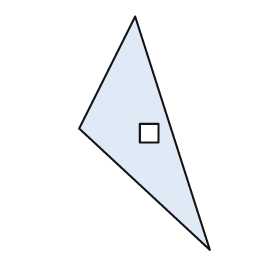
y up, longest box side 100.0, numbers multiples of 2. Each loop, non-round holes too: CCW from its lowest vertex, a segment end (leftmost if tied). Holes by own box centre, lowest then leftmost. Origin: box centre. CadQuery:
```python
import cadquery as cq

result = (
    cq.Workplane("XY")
    .moveTo(28.0, -50.0)
    .lineTo(-4.0, 50.0)
    .lineTo(-28.0, 2.0)
    .close()
    .moveTo(-2.0, -4.0)
    .lineTo(6.0, -4.0)
    .lineTo(6.0, 4.0)
    .lineTo(-2.0, 4.0)
    .close()
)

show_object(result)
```